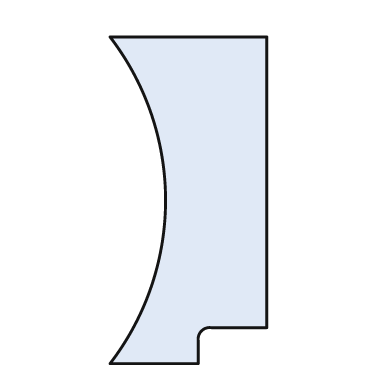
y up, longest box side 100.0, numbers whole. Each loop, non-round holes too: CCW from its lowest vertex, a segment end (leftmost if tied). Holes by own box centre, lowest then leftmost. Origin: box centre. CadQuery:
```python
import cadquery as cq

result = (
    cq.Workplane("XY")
    .moveTo(-24.0, -50.0)
    .lineTo(3.0, -50.0)
    .lineTo(3.0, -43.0)
    .threePointArc((4.0, -40.0), (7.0, -39.0))
    .lineTo(24.0, -39.0)
    .lineTo(24.0, 50.0)
    .lineTo(-24.0, 50.0)
    .threePointArc((-7.0, 0.0), (-24.0, -50.0))
    .close()
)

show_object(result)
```